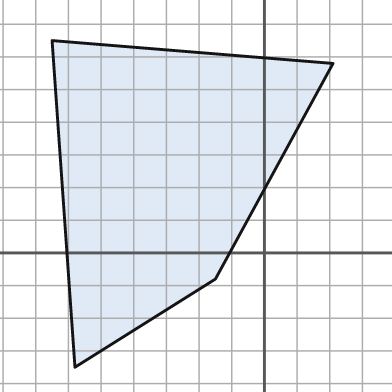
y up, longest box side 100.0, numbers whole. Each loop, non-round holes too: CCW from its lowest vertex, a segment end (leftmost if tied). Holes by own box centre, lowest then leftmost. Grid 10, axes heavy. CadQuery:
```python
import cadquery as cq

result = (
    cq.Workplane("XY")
    .moveTo(-58.0, -35.0)
    .lineTo(-15.0, -8.0)
    .lineTo(21.0, 58.0)
    .lineTo(-65.0, 65.0)
    .close()
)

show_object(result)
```